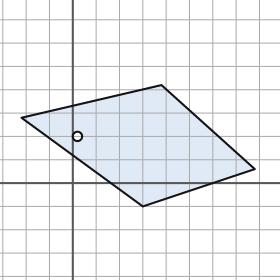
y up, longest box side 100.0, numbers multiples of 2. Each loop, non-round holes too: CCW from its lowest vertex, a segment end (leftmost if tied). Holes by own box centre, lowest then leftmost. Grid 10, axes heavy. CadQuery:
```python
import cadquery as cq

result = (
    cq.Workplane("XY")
    .moveTo(30.0, -10.0)
    .lineTo(78.0, 6.0)
    .lineTo(38.0, 42.0)
    .lineTo(-22.0, 28.0)
    .close()
    .moveTo(2.0, 20.0)
    .circle(2.0)
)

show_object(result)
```